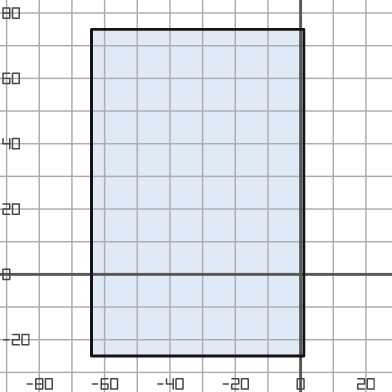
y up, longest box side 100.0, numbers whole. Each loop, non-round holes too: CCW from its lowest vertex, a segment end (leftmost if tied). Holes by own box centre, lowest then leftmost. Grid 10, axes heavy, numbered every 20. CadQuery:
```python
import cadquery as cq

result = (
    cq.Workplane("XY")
    .moveTo(-64.0, -25.0)
    .lineTo(1.0, -25.0)
    .lineTo(1.0, 75.0)
    .lineTo(-64.0, 75.0)
    .close()
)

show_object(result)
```